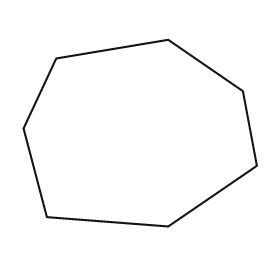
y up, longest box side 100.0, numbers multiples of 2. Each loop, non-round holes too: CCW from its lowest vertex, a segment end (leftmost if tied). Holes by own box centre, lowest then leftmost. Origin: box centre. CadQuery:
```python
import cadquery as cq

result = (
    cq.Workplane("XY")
    .moveTo(12.0, -40.0)
    .lineTo(50.0, -14.0)
    .lineTo(44.0, 18.0)
    .lineTo(12.0, 40.0)
    .lineTo(-36.0, 32.0)
    .lineTo(-50.0, 2.0)
    .lineTo(-40.0, -36.0)
    .close()
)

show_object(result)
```